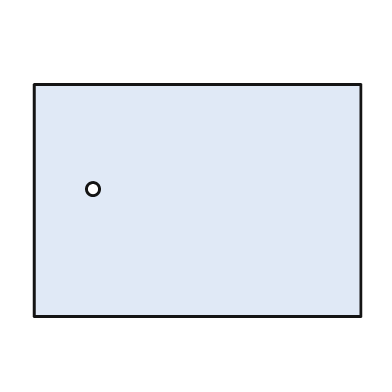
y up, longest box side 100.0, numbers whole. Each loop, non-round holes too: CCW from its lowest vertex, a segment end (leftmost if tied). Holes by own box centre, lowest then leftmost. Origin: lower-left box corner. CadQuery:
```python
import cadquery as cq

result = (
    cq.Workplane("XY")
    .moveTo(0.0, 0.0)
    .lineTo(100.0, 0.0)
    .lineTo(100.0, 71.0)
    .lineTo(0.0, 71.0)
    .close()
    .moveTo(18.0, 39.0)
    .circle(2.0)
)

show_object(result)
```